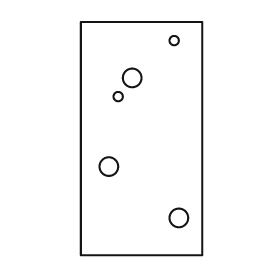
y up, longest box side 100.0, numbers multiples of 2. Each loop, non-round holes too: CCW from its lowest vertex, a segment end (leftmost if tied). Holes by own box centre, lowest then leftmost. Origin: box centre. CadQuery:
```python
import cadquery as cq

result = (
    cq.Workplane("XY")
    .moveTo(-26.0, -50.0)
    .lineTo(26.0, -50.0)
    .lineTo(26.0, 50.0)
    .lineTo(-26.0, 50.0)
    .close()
    .moveTo(16.0, -34.0)
    .circle(4.0)
    .moveTo(-14.0, -12.0)
    .circle(4.0)
    .moveTo(-10.0, 18.0)
    .circle(2.0)
    .moveTo(-4.0, 26.0)
    .circle(4.0)
    .moveTo(14.0, 42.0)
    .circle(2.0)
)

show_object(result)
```